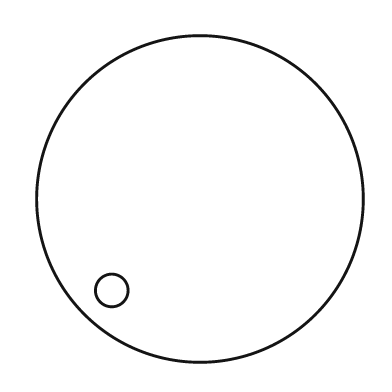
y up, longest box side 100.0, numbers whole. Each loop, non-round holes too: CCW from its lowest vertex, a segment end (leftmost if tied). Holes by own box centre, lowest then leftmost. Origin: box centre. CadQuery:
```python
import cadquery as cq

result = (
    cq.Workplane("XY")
    .moveTo(0.0, 0.0)
    .circle(50.0)
    .moveTo(-27.0, -28.0)
    .circle(5.0)
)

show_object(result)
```